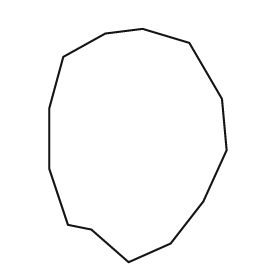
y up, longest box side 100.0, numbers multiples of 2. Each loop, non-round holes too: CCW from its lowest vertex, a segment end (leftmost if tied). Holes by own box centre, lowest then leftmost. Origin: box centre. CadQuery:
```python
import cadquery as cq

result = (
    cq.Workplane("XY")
    .moveTo(-4.0, -50.0)
    .lineTo(14.0, -42.0)
    .lineTo(28.0, -24.0)
    .lineTo(38.0, -2.0)
    .lineTo(36.0, 20.0)
    .lineTo(22.0, 44.0)
    .lineTo(2.0, 50.0)
    .lineTo(-14.0, 48.0)
    .lineTo(-32.0, 38.0)
    .lineTo(-38.0, 16.0)
    .lineTo(-38.0, -10.0)
    .lineTo(-30.0, -34.0)
    .lineTo(-20.0, -36.0)
    .close()
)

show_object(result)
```